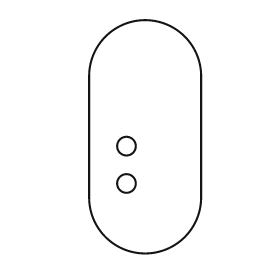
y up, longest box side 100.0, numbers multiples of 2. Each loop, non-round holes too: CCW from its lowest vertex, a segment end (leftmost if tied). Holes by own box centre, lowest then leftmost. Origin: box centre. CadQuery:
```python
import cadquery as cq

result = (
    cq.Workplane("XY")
    .moveTo(-24.0, -26.0)
    .threePointArc((0.0, -50.0), (24.0, -26.0))
    .lineTo(24.0, 26.0)
    .threePointArc((0.0, 50.0), (-24.0, 26.0))
    .close()
    .moveTo(-8.0, -20.0)
    .circle(4.0)
    .moveTo(-8.0, -4.0)
    .circle(4.0)
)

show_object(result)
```